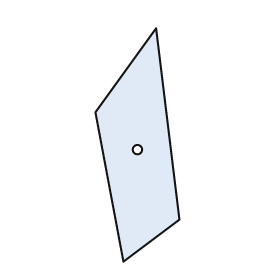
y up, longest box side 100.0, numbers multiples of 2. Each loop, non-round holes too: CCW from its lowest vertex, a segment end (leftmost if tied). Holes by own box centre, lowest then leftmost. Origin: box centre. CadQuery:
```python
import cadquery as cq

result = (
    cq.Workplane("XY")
    .moveTo(-6.0, -50.0)
    .lineTo(18.0, -32.0)
    .lineTo(8.0, 50.0)
    .lineTo(-18.0, 14.0)
    .close()
    .moveTo(0.0, -2.0)
    .circle(2.0)
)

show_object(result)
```